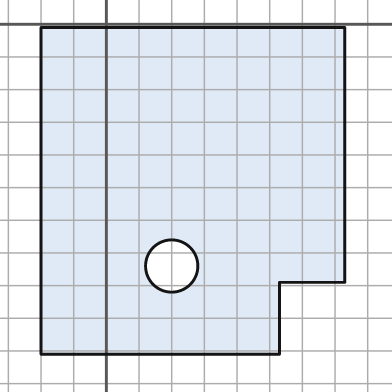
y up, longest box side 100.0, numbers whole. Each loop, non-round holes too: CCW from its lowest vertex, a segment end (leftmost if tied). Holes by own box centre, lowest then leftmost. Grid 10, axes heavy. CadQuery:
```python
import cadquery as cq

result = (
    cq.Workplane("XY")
    .moveTo(-20.0, -101.0)
    .lineTo(53.0, -101.0)
    .lineTo(53.0, -79.0)
    .lineTo(73.0, -79.0)
    .lineTo(73.0, -1.0)
    .lineTo(-20.0, -1.0)
    .close()
    .moveTo(20.0, -74.0)
    .circle(8.0)
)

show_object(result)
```